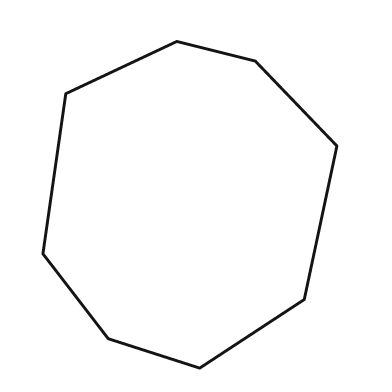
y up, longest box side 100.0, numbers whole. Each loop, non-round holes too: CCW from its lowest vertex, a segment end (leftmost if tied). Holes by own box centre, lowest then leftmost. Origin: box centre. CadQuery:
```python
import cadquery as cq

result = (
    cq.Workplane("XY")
    .moveTo(3.0, -50.0)
    .lineTo(35.0, -29.0)
    .lineTo(45.0, 18.0)
    .lineTo(20.0, 44.0)
    .lineTo(-4.0, 50.0)
    .lineTo(-38.0, 34.0)
    .lineTo(-45.0, -15.0)
    .lineTo(-25.0, -41.0)
    .close()
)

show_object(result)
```